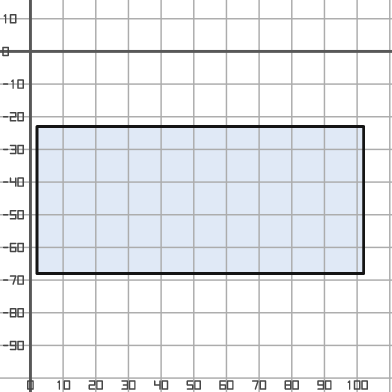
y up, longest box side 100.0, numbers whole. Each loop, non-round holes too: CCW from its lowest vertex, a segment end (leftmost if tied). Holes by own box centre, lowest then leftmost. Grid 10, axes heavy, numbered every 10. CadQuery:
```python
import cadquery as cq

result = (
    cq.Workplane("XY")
    .moveTo(2.0, -68.0)
    .lineTo(102.0, -68.0)
    .lineTo(102.0, -23.0)
    .lineTo(2.0, -23.0)
    .close()
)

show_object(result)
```